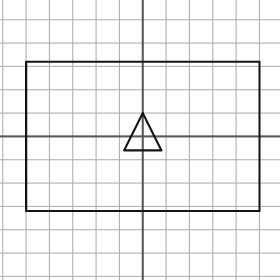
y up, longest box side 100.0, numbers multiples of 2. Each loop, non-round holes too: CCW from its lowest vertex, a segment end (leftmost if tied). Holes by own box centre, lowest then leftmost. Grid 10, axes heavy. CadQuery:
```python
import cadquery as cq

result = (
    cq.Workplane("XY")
    .moveTo(-50.0, -32.0)
    .lineTo(50.0, -32.0)
    .lineTo(50.0, 32.0)
    .lineTo(-50.0, 32.0)
    .close()
    .moveTo(-8.0, -6.0)
    .lineTo(8.0, -6.0)
    .lineTo(0.0, 10.0)
    .close()
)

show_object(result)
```